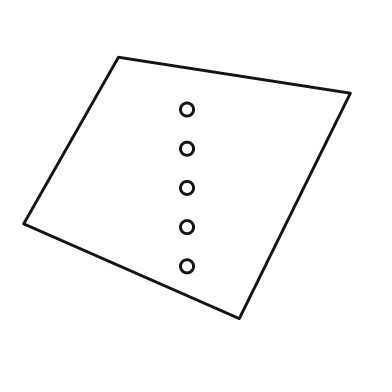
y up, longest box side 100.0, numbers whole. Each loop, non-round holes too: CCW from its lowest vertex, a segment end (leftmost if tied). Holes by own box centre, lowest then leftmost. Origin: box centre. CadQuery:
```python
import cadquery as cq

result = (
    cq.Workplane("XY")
    .moveTo(16.0, -40.0)
    .lineTo(50.0, 29.0)
    .lineTo(-21.0, 40.0)
    .lineTo(-50.0, -11.0)
    .close()
    .moveTo(0.0, -24.0)
    .circle(2.0)
    .moveTo(0.0, -12.0)
    .circle(2.0)
    .moveTo(0.0, 0.0)
    .circle(2.0)
    .moveTo(0.0, 12.0)
    .circle(2.0)
    .moveTo(0.0, 24.0)
    .circle(2.0)
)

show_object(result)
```